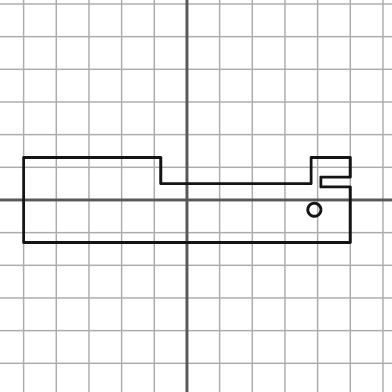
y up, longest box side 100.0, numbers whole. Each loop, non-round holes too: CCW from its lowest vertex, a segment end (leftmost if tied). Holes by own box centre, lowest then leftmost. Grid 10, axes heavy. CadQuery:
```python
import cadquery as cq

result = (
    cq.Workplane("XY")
    .moveTo(-50.0, -13.0)
    .lineTo(50.0, -13.0)
    .lineTo(50.0, 4.0)
    .lineTo(41.0, 4.0)
    .lineTo(41.0, 7.0)
    .lineTo(50.0, 7.0)
    .lineTo(50.0, 13.0)
    .lineTo(38.0, 13.0)
    .lineTo(38.0, 5.0)
    .lineTo(-8.0, 5.0)
    .lineTo(-8.0, 13.0)
    .lineTo(-50.0, 13.0)
    .close()
    .moveTo(39.0, -3.0)
    .circle(2.0)
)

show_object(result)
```